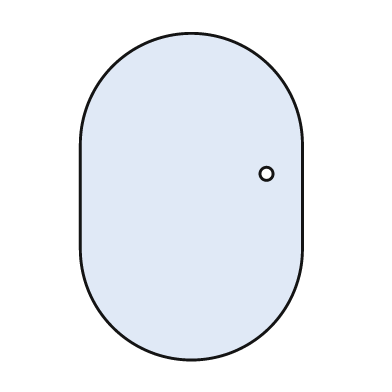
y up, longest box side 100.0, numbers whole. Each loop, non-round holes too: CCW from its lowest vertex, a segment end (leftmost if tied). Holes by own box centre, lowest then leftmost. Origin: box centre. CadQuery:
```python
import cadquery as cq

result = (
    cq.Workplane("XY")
    .moveTo(-34.0, -16.0)
    .threePointArc((0.0, -50.0), (34.0, -16.0))
    .lineTo(34.0, 16.0)
    .threePointArc((0.0, 50.0), (-34.0, 16.0))
    .close()
    .moveTo(23.0, 7.0)
    .circle(2.0)
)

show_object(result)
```